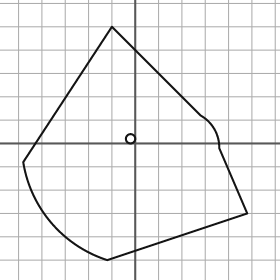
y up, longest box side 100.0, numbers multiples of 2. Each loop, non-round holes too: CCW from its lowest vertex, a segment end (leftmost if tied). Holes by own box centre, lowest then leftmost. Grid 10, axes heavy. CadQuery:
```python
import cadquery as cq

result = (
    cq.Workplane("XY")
    .moveTo(-12.0, -50.0)
    .lineTo(48.0, -30.0)
    .lineTo(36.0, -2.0)
    .threePointArc((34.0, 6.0), (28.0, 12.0))
    .lineTo(-10.0, 50.0)
    .lineTo(-48.0, -8.0)
    .threePointArc((-36.0, -34.0), (-12.0, -50.0))
    .close()
    .moveTo(-2.0, 2.0)
    .circle(2.0)
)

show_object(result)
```